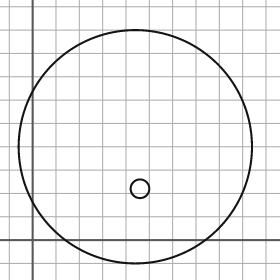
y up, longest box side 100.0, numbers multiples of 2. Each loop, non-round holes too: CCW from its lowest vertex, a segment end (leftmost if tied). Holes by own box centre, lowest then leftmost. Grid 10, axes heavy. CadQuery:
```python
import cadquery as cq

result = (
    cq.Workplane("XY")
    .moveTo(44.0, 40.0)
    .circle(50.0)
    .moveTo(46.0, 22.0)
    .circle(4.0)
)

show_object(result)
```